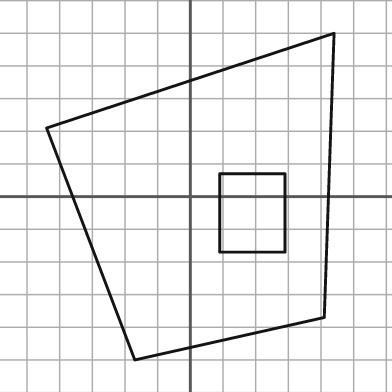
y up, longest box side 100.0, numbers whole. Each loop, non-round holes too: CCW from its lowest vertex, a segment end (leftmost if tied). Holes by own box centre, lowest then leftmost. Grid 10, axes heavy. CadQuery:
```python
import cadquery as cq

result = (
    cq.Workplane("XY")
    .moveTo(-17.0, -50.0)
    .lineTo(41.0, -37.0)
    .lineTo(44.0, 50.0)
    .lineTo(-44.0, 21.0)
    .close()
    .moveTo(9.0, -17.0)
    .lineTo(29.0, -17.0)
    .lineTo(29.0, 7.0)
    .lineTo(9.0, 7.0)
    .close()
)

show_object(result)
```